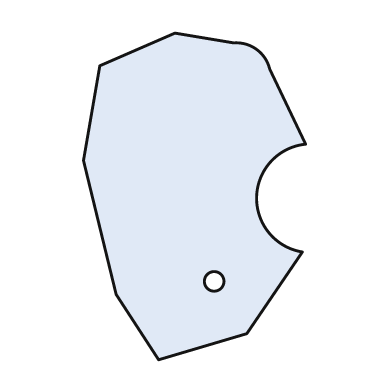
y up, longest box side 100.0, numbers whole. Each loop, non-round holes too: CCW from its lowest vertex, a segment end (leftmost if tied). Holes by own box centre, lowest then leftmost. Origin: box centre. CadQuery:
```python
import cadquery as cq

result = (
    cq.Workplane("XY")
    .moveTo(-11.0, -50.0)
    .lineTo(16.0, -42.0)
    .lineTo(33.0, -17.0)
    .threePointArc((19.0, 0.0), (34.0, 16.0))
    .lineTo(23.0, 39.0)
    .threePointArc((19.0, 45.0), (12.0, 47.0))
    .lineTo(-6.0, 50.0)
    .lineTo(-29.0, 40.0)
    .lineTo(-34.0, 11.0)
    .lineTo(-24.0, -30.0)
    .close()
    .moveTo(6.0, -26.0)
    .circle(3.0)
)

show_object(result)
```